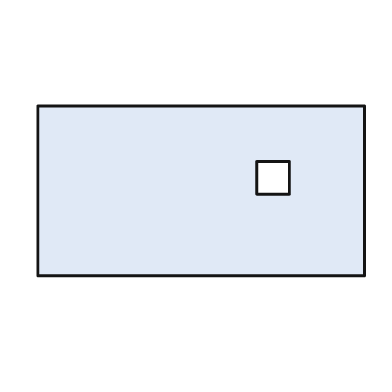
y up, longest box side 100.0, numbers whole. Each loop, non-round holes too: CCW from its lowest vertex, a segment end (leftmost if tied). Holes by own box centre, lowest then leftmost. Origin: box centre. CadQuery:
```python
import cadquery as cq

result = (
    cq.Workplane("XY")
    .moveTo(-50.0, -26.0)
    .lineTo(50.0, -26.0)
    .lineTo(50.0, 26.0)
    .lineTo(-50.0, 26.0)
    .close()
    .moveTo(17.0, -1.0)
    .lineTo(27.0, -1.0)
    .lineTo(27.0, 9.0)
    .lineTo(17.0, 9.0)
    .close()
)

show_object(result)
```